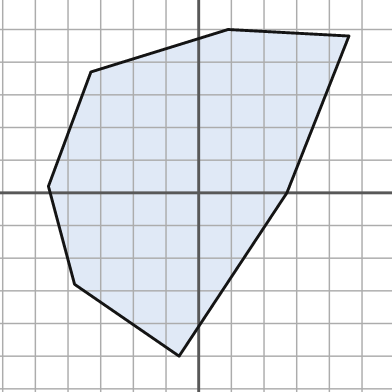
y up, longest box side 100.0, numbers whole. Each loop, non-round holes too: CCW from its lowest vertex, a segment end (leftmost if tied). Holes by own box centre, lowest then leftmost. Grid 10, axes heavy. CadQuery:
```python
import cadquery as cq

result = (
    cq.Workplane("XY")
    .moveTo(-6.0, -50.0)
    .lineTo(27.0, 0.0)
    .lineTo(46.0, 48.0)
    .lineTo(9.0, 50.0)
    .lineTo(-33.0, 37.0)
    .lineTo(-46.0, 2.0)
    .lineTo(-38.0, -28.0)
    .close()
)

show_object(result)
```